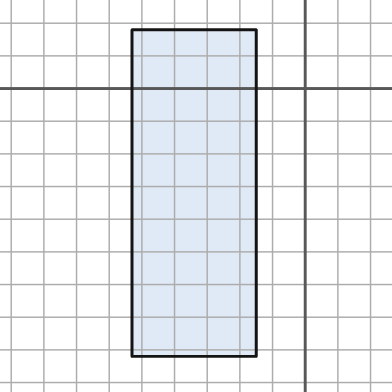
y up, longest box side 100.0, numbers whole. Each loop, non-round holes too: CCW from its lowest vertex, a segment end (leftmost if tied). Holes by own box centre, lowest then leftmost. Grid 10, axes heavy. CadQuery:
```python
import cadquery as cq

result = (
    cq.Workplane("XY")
    .moveTo(-53.0, -82.0)
    .lineTo(-15.0, -82.0)
    .lineTo(-15.0, 18.0)
    .lineTo(-53.0, 18.0)
    .close()
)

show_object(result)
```